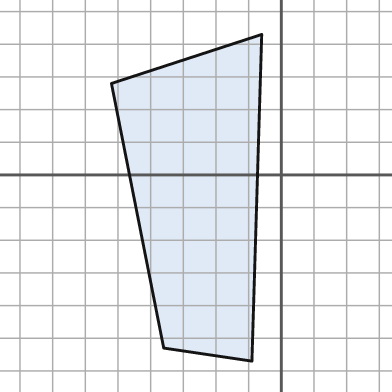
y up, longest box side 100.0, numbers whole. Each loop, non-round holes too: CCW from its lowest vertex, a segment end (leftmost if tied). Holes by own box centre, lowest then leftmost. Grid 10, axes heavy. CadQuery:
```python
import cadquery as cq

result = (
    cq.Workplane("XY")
    .moveTo(-9.0, -57.0)
    .lineTo(-6.0, 43.0)
    .lineTo(-52.0, 28.0)
    .lineTo(-36.0, -53.0)
    .close()
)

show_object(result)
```